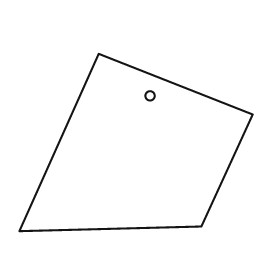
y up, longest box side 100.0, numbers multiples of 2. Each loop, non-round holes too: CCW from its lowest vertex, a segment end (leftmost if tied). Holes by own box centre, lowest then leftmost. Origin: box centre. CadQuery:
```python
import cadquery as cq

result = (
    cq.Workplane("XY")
    .moveTo(-50.0, -38.0)
    .lineTo(28.0, -36.0)
    .lineTo(50.0, 12.0)
    .lineTo(-16.0, 38.0)
    .close()
    .moveTo(6.0, 20.0)
    .circle(2.0)
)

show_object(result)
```